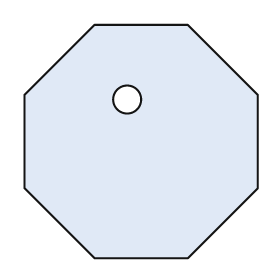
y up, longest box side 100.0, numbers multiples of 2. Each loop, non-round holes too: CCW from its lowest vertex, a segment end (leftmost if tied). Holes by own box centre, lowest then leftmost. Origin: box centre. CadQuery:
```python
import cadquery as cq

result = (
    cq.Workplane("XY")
    .moveTo(-20.0, -50.0)
    .lineTo(20.0, -50.0)
    .lineTo(50.0, -20.0)
    .lineTo(50.0, 20.0)
    .lineTo(20.0, 50.0)
    .lineTo(-20.0, 50.0)
    .lineTo(-50.0, 20.0)
    .lineTo(-50.0, -20.0)
    .close()
    .moveTo(-6.0, 18.0)
    .circle(6.0)
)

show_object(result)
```